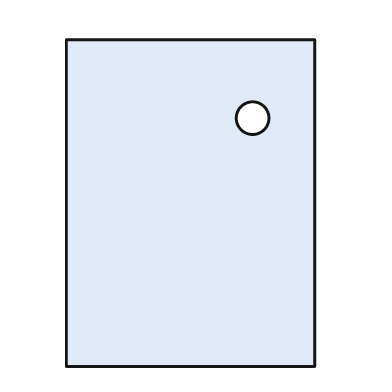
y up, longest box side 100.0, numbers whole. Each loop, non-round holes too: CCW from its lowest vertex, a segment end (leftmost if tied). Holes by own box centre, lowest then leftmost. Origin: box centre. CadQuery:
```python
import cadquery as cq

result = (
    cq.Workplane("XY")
    .moveTo(-38.0, -50.0)
    .lineTo(38.0, -50.0)
    .lineTo(38.0, 50.0)
    .lineTo(-38.0, 50.0)
    .close()
    .moveTo(19.0, 26.0)
    .circle(5.0)
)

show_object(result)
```